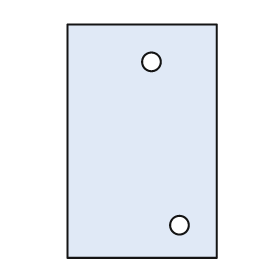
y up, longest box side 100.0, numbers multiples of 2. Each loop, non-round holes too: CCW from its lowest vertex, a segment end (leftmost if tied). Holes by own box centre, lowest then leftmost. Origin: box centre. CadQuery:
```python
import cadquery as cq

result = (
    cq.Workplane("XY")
    .moveTo(-32.0, -50.0)
    .lineTo(32.0, -50.0)
    .lineTo(32.0, 50.0)
    .lineTo(-32.0, 50.0)
    .close()
    .moveTo(16.0, -36.0)
    .circle(4.0)
    .moveTo(4.0, 34.0)
    .circle(4.0)
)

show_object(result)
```